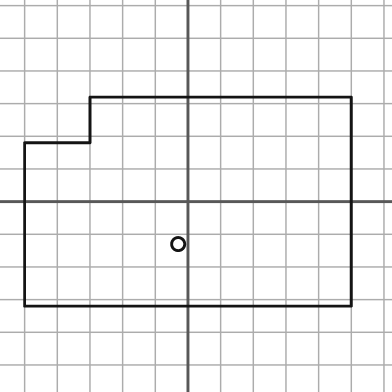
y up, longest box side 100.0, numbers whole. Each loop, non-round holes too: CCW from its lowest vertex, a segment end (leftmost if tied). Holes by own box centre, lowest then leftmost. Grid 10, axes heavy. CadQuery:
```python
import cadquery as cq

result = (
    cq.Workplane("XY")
    .moveTo(-50.0, -32.0)
    .lineTo(50.0, -32.0)
    .lineTo(50.0, 32.0)
    .lineTo(-30.0, 32.0)
    .lineTo(-30.0, 18.0)
    .lineTo(-50.0, 18.0)
    .close()
    .moveTo(-3.0, -13.0)
    .circle(2.0)
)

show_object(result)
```